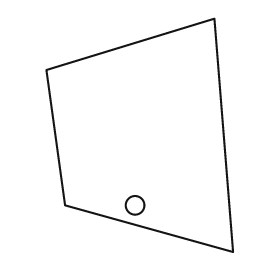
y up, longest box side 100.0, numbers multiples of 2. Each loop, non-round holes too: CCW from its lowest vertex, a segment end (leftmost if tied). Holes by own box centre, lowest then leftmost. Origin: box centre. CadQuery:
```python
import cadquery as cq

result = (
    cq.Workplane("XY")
    .moveTo(40.0, -50.0)
    .lineTo(32.0, 50.0)
    .lineTo(-40.0, 28.0)
    .lineTo(-32.0, -30.0)
    .close()
    .moveTo(-2.0, -30.0)
    .circle(4.0)
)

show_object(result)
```